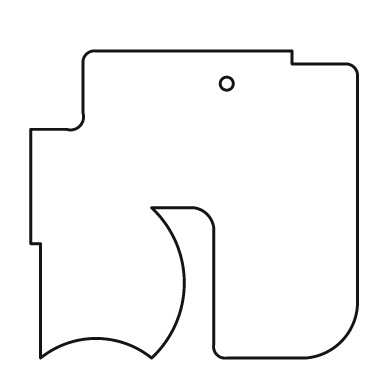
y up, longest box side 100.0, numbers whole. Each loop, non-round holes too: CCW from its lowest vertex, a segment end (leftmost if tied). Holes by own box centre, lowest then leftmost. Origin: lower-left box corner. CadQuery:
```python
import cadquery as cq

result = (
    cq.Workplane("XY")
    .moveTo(3.0, 0.0)
    .threePointArc((20.0, 6.0), (37.0, 0.0))
    .threePointArc((47.0, 23.0), (37.0, 46.0))
    .lineTo(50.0, 46.0)
    .threePointArc((54.0, 44.0), (56.0, 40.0))
    .lineTo(56.0, 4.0)
    .threePointArc((57.0, 1.0), (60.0, 0.0))
    .lineTo(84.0, 0.0)
    .threePointArc((95.0, 5.0), (100.0, 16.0))
    .lineTo(100.0, 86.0)
    .threePointArc((99.0, 89.0), (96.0, 90.0))
    .lineTo(80.0, 90.0)
    .lineTo(80.0, 94.0)
    .lineTo(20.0, 94.0)
    .threePointArc((17.0, 93.0), (16.0, 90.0))
    .lineTo(16.0, 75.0)
    .threePointArc((15.0, 71.0), (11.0, 70.0))
    .lineTo(0.0, 70.0)
    .lineTo(0.0, 35.0)
    .lineTo(3.0, 35.0)
    .close()
    .moveTo(60.0, 84.0)
    .circle(2.0)
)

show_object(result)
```